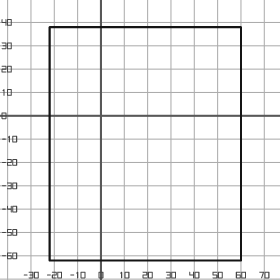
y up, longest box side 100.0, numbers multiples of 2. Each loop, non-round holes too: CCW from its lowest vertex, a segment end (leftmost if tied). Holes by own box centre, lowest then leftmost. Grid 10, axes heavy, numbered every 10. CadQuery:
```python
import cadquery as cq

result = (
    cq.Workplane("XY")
    .moveTo(-22.0, -62.0)
    .lineTo(60.0, -62.0)
    .lineTo(60.0, 38.0)
    .lineTo(-22.0, 38.0)
    .close()
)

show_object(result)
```